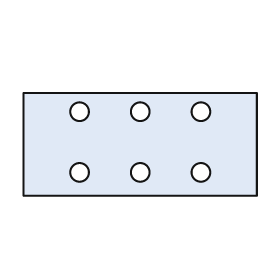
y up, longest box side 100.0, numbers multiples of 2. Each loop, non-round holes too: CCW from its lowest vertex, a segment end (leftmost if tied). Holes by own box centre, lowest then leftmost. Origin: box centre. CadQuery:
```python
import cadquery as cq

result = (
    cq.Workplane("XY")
    .moveTo(-50.0, -22.0)
    .lineTo(50.0, -22.0)
    .lineTo(50.0, 22.0)
    .lineTo(-50.0, 22.0)
    .close()
    .moveTo(-26.0, -12.0)
    .circle(4.0)
    .moveTo(0.0, -12.0)
    .circle(4.0)
    .moveTo(26.0, -12.0)
    .circle(4.0)
    .moveTo(-26.0, 14.0)
    .circle(4.0)
    .moveTo(0.0, 14.0)
    .circle(4.0)
    .moveTo(26.0, 14.0)
    .circle(4.0)
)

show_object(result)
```